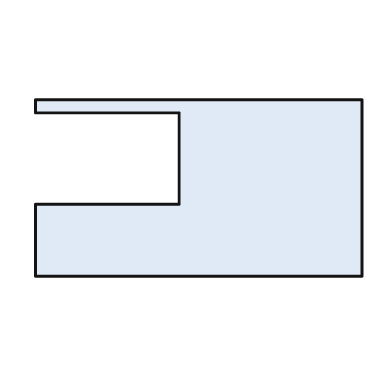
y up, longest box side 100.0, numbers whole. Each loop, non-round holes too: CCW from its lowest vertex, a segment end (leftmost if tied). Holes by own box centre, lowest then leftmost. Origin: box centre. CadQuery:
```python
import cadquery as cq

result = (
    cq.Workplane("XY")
    .moveTo(-50.0, -27.0)
    .lineTo(50.0, -27.0)
    .lineTo(50.0, 27.0)
    .lineTo(-50.0, 27.0)
    .lineTo(-50.0, 23.0)
    .lineTo(-6.0, 23.0)
    .lineTo(-6.0, -5.0)
    .lineTo(-50.0, -5.0)
    .close()
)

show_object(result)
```